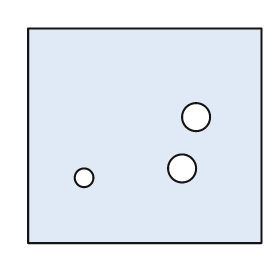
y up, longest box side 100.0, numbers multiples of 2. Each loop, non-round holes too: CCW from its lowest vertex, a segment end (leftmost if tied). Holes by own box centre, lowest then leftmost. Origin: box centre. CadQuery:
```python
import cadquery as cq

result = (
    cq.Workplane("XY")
    .moveTo(-50.0, -46.0)
    .lineTo(50.0, -46.0)
    .lineTo(50.0, 46.0)
    .lineTo(-50.0, 46.0)
    .close()
    .moveTo(-26.0, -18.0)
    .circle(4.0)
    .moveTo(16.0, -14.0)
    .circle(6.0)
    .moveTo(22.0, 8.0)
    .circle(6.0)
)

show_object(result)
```